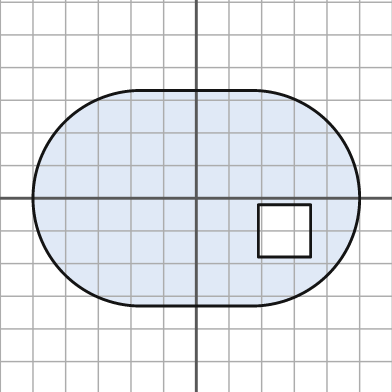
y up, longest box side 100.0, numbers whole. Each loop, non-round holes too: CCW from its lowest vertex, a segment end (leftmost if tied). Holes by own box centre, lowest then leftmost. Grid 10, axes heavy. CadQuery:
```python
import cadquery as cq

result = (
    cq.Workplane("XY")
    .moveTo(-17.0, -33.0)
    .lineTo(17.0, -33.0)
    .threePointArc((50.0, 0.0), (17.0, 33.0))
    .lineTo(-17.0, 33.0)
    .threePointArc((-50.0, 0.0), (-17.0, -33.0))
    .close()
    .moveTo(19.0, -18.0)
    .lineTo(35.0, -18.0)
    .lineTo(35.0, -2.0)
    .lineTo(19.0, -2.0)
    .close()
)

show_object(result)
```